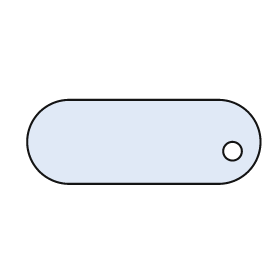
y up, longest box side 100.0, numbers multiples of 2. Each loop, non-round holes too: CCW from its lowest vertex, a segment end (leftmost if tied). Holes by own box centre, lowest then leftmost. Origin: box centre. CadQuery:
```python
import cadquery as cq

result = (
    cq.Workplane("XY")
    .moveTo(-32.0, -18.0)
    .lineTo(32.0, -18.0)
    .threePointArc((50.0, 0.0), (32.0, 18.0))
    .lineTo(-32.0, 18.0)
    .threePointArc((-50.0, 0.0), (-32.0, -18.0))
    .close()
    .moveTo(38.0, -4.0)
    .circle(4.0)
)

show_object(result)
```